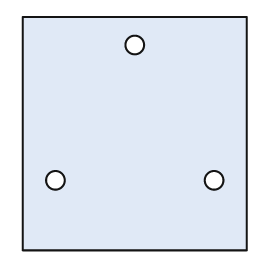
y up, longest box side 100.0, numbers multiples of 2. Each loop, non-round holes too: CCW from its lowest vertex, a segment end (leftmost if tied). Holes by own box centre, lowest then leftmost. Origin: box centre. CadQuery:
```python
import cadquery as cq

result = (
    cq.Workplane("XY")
    .moveTo(-48.0, -50.0)
    .lineTo(48.0, -50.0)
    .lineTo(48.0, 50.0)
    .lineTo(-48.0, 50.0)
    .close()
    .moveTo(-34.0, -20.0)
    .circle(4.0)
    .moveTo(34.0, -20.0)
    .circle(4.0)
    .moveTo(0.0, 38.0)
    .circle(4.0)
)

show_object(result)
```